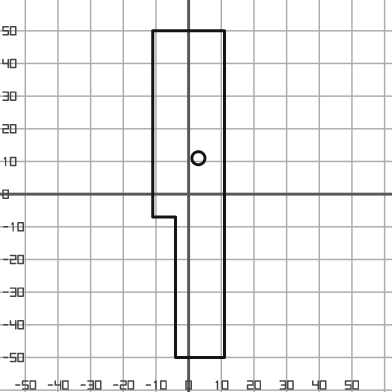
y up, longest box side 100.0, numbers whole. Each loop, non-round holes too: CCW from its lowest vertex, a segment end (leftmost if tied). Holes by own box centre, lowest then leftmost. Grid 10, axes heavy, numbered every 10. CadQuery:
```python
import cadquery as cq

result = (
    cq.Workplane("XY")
    .moveTo(-4.0, -50.0)
    .lineTo(11.0, -50.0)
    .lineTo(11.0, 50.0)
    .lineTo(-11.0, 50.0)
    .lineTo(-11.0, -7.0)
    .lineTo(-4.0, -7.0)
    .close()
    .moveTo(3.0, 11.0)
    .circle(2.0)
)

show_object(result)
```